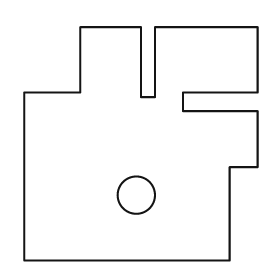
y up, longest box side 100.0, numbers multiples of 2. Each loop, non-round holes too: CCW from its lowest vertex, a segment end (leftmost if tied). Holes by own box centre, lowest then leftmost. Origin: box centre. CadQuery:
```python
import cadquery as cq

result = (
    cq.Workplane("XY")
    .moveTo(-50.0, -50.0)
    .lineTo(38.0, -50.0)
    .lineTo(38.0, -10.0)
    .lineTo(50.0, -10.0)
    .lineTo(50.0, 14.0)
    .lineTo(18.0, 14.0)
    .lineTo(18.0, 22.0)
    .lineTo(50.0, 22.0)
    .lineTo(50.0, 50.0)
    .lineTo(6.0, 50.0)
    .lineTo(6.0, 20.0)
    .lineTo(0.0, 20.0)
    .lineTo(0.0, 50.0)
    .lineTo(-26.0, 50.0)
    .lineTo(-26.0, 22.0)
    .lineTo(-50.0, 22.0)
    .close()
    .moveTo(-2.0, -22.0)
    .circle(8.0)
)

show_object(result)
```